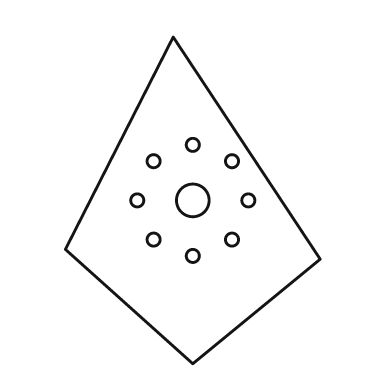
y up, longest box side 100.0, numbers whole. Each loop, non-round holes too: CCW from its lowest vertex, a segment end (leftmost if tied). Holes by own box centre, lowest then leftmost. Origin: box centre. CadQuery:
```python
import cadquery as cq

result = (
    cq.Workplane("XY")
    .moveTo(0.0, -50.0)
    .lineTo(39.0, -18.0)
    .lineTo(-6.0, 50.0)
    .lineTo(-39.0, -15.0)
    .close()
    .moveTo(0.0, -17.0)
    .circle(2.0)
    .moveTo(-12.0, -12.0)
    .circle(2.0)
    .moveTo(12.0, -12.0)
    .circle(2.0)
    .moveTo(-17.0, 0.0)
    .circle(2.0)
    .moveTo(0.0, 0.0)
    .circle(5.0)
    .moveTo(17.0, 0.0)
    .circle(2.0)
    .moveTo(-12.0, 12.0)
    .circle(2.0)
    .moveTo(12.0, 12.0)
    .circle(2.0)
    .moveTo(0.0, 17.0)
    .circle(2.0)
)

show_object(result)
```